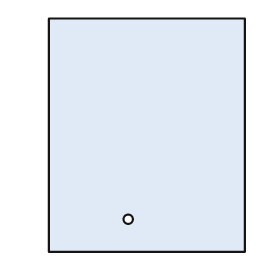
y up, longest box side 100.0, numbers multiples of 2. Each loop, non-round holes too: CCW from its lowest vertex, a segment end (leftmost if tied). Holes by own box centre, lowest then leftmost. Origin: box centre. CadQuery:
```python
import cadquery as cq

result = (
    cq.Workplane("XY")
    .moveTo(-42.0, -50.0)
    .lineTo(42.0, -50.0)
    .lineTo(42.0, 50.0)
    .lineTo(-42.0, 50.0)
    .close()
    .moveTo(-8.0, -36.0)
    .circle(2.0)
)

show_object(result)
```